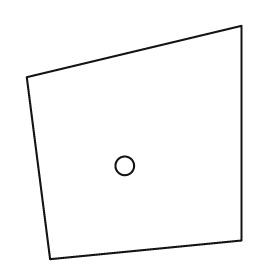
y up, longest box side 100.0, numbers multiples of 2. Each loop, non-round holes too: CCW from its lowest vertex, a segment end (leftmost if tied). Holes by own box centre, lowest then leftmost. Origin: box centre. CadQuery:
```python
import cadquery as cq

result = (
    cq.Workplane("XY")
    .moveTo(-36.0, -50.0)
    .lineTo(46.0, -42.0)
    .lineTo(46.0, 50.0)
    .lineTo(-46.0, 28.0)
    .close()
    .moveTo(-4.0, -10.0)
    .circle(4.0)
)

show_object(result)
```